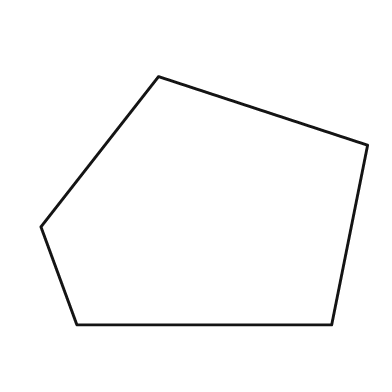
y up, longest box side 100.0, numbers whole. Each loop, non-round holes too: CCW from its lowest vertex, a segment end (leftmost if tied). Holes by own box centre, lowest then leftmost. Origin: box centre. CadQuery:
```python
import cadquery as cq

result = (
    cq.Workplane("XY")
    .moveTo(-39.0, -38.0)
    .lineTo(39.0, -38.0)
    .lineTo(50.0, 17.0)
    .lineTo(-14.0, 38.0)
    .lineTo(-50.0, -8.0)
    .close()
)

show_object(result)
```